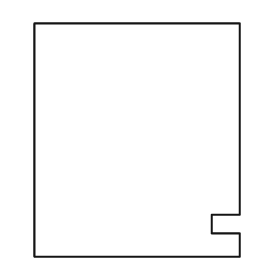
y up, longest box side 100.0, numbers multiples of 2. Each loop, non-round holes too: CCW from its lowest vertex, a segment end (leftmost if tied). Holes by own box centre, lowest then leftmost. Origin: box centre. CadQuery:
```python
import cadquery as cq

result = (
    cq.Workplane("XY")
    .moveTo(-44.0, -50.0)
    .lineTo(44.0, -50.0)
    .lineTo(44.0, -40.0)
    .lineTo(32.0, -40.0)
    .lineTo(32.0, -32.0)
    .lineTo(44.0, -32.0)
    .lineTo(44.0, 50.0)
    .lineTo(-44.0, 50.0)
    .close()
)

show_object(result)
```